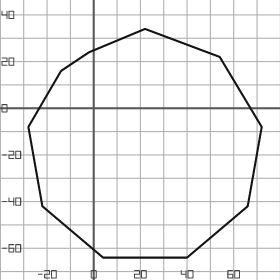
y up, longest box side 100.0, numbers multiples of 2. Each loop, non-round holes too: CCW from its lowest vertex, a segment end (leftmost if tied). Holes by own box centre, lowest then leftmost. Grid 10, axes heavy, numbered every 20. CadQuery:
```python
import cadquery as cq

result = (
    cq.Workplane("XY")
    .moveTo(4.0, -64.0)
    .lineTo(40.0, -64.0)
    .lineTo(66.0, -42.0)
    .lineTo(72.0, -8.0)
    .lineTo(54.0, 22.0)
    .lineTo(22.0, 34.0)
    .lineTo(-2.0, 24.0)
    .lineTo(-14.0, 16.0)
    .lineTo(-28.0, -8.0)
    .lineTo(-22.0, -42.0)
    .close()
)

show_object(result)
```